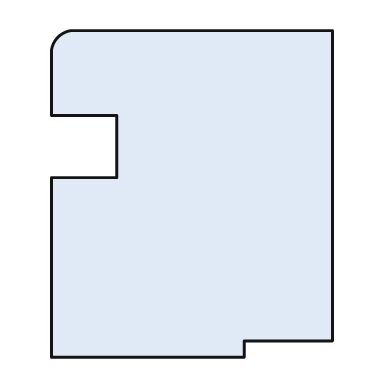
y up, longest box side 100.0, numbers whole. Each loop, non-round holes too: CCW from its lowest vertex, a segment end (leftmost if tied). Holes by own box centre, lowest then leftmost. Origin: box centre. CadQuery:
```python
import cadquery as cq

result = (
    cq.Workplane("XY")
    .moveTo(-43.0, -50.0)
    .lineTo(16.0, -50.0)
    .lineTo(16.0, -45.0)
    .lineTo(43.0, -45.0)
    .lineTo(43.0, 50.0)
    .lineTo(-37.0, 50.0)
    .threePointArc((-41.0, 48.0), (-43.0, 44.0))
    .lineTo(-43.0, 24.0)
    .lineTo(-23.0, 24.0)
    .lineTo(-23.0, 5.0)
    .lineTo(-43.0, 5.0)
    .close()
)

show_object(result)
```